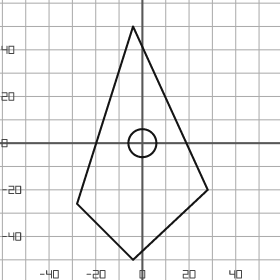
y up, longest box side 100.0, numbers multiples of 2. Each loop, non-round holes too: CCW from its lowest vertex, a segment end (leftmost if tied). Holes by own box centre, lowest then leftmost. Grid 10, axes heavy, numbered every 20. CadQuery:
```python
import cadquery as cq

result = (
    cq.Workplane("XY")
    .moveTo(-4.0, -50.0)
    .lineTo(28.0, -20.0)
    .lineTo(-4.0, 50.0)
    .lineTo(-28.0, -26.0)
    .close()
    .moveTo(0.0, 0.0)
    .circle(6.0)
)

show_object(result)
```